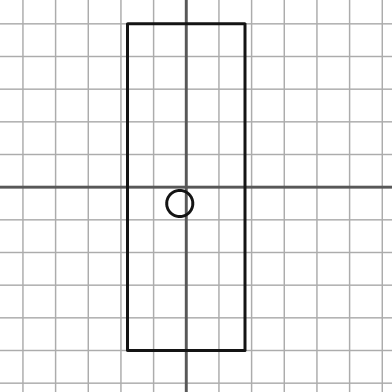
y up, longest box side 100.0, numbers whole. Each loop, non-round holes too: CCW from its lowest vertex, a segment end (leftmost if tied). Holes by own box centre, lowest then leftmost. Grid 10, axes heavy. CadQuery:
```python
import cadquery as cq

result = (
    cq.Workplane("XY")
    .moveTo(-18.0, -50.0)
    .lineTo(18.0, -50.0)
    .lineTo(18.0, 50.0)
    .lineTo(-18.0, 50.0)
    .close()
    .moveTo(-2.0, -5.0)
    .circle(4.0)
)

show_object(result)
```